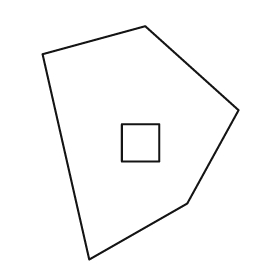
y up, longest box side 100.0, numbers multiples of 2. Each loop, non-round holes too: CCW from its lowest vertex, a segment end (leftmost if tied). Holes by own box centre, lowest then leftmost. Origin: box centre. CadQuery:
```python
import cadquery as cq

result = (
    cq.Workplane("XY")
    .moveTo(-22.0, -50.0)
    .lineTo(20.0, -26.0)
    .lineTo(42.0, 14.0)
    .lineTo(2.0, 50.0)
    .lineTo(-42.0, 38.0)
    .close()
    .moveTo(-8.0, -8.0)
    .lineTo(8.0, -8.0)
    .lineTo(8.0, 8.0)
    .lineTo(-8.0, 8.0)
    .close()
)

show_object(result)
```